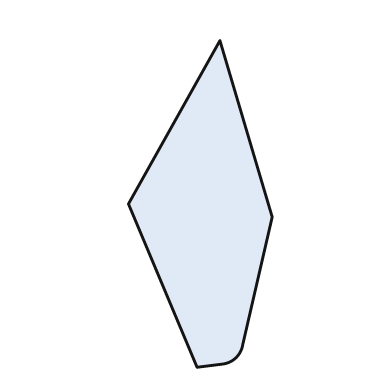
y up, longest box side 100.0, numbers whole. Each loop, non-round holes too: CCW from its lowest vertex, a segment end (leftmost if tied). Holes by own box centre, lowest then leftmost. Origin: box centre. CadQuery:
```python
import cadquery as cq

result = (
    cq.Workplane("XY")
    .moveTo(-1.0, -50.0)
    .lineTo(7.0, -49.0)
    .threePointArc((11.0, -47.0), (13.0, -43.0))
    .lineTo(22.0, -4.0)
    .lineTo(6.0, 50.0)
    .lineTo(-22.0, 0.0)
    .close()
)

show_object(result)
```